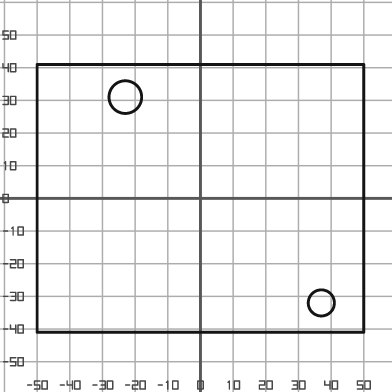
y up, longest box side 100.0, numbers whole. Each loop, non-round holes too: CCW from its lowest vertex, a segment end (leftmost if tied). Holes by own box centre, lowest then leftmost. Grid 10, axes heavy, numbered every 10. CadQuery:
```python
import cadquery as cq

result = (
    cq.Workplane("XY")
    .moveTo(-50.0, -41.0)
    .lineTo(50.0, -41.0)
    .lineTo(50.0, 41.0)
    .lineTo(-50.0, 41.0)
    .close()
    .moveTo(37.0, -32.0)
    .circle(4.0)
    .moveTo(-23.0, 31.0)
    .circle(5.0)
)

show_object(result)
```